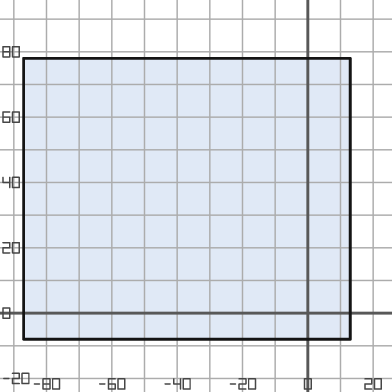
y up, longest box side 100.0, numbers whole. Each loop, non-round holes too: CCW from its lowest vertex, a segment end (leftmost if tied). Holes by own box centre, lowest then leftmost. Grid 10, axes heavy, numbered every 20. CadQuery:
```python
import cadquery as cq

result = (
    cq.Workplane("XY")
    .moveTo(-87.0, -8.0)
    .lineTo(13.0, -8.0)
    .lineTo(13.0, 78.0)
    .lineTo(-87.0, 78.0)
    .close()
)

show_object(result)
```